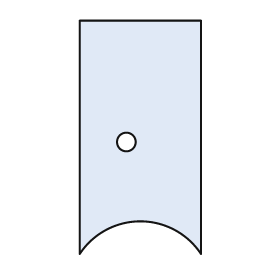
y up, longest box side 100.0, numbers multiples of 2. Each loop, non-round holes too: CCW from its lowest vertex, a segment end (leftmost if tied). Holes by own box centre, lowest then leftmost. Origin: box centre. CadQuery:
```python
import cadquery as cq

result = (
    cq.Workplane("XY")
    .moveTo(-26.0, -50.0)
    .threePointArc((0.0, -36.0), (26.0, -50.0))
    .lineTo(26.0, 50.0)
    .lineTo(-26.0, 50.0)
    .close()
    .moveTo(-6.0, -2.0)
    .circle(4.0)
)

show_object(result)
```